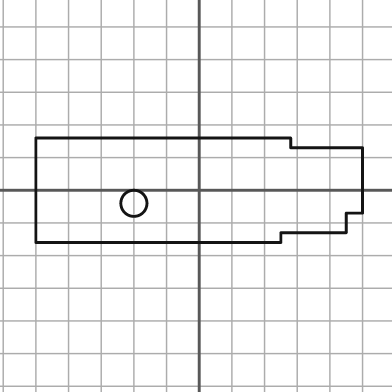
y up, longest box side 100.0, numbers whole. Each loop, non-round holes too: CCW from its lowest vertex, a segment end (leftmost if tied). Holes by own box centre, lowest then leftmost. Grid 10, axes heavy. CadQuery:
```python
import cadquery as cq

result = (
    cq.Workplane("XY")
    .moveTo(-50.0, -16.0)
    .lineTo(25.0, -16.0)
    .lineTo(25.0, -13.0)
    .lineTo(45.0, -13.0)
    .lineTo(45.0, -7.0)
    .lineTo(50.0, -7.0)
    .lineTo(50.0, 13.0)
    .lineTo(28.0, 13.0)
    .lineTo(28.0, 16.0)
    .lineTo(-50.0, 16.0)
    .close()
    .moveTo(-20.0, -4.0)
    .circle(4.0)
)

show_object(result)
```